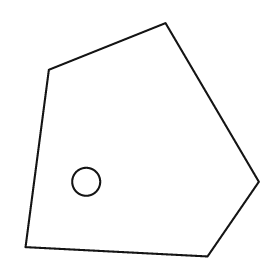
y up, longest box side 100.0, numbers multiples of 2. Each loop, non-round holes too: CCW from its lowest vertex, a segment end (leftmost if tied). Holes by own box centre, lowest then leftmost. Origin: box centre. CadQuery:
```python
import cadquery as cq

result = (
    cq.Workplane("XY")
    .moveTo(28.0, -50.0)
    .lineTo(50.0, -18.0)
    .lineTo(10.0, 50.0)
    .lineTo(-40.0, 30.0)
    .lineTo(-50.0, -46.0)
    .close()
    .moveTo(-24.0, -18.0)
    .circle(6.0)
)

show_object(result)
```